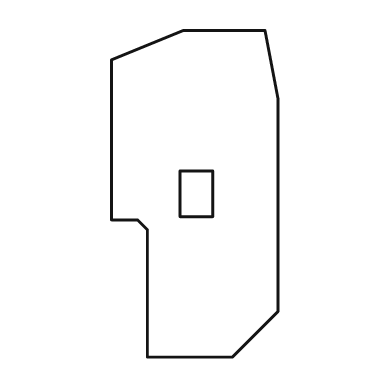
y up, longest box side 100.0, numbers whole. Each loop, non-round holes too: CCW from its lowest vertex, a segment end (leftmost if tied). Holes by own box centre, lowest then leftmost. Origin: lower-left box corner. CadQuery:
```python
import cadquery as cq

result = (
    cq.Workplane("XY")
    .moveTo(11.0, 0.0)
    .lineTo(37.0, 0.0)
    .lineTo(51.0, 14.0)
    .lineTo(51.0, 79.0)
    .lineTo(47.0, 100.0)
    .lineTo(22.0, 100.0)
    .lineTo(0.0, 91.0)
    .lineTo(0.0, 42.0)
    .lineTo(8.0, 42.0)
    .lineTo(11.0, 39.0)
    .close()
    .moveTo(21.0, 43.0)
    .lineTo(31.0, 43.0)
    .lineTo(31.0, 57.0)
    .lineTo(21.0, 57.0)
    .close()
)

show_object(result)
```